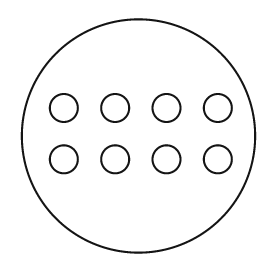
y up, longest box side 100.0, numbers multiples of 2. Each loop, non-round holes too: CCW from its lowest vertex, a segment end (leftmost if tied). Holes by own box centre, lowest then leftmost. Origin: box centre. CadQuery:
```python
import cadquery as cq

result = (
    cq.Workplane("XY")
    .moveTo(0.0, 0.0)
    .circle(50.0)
    .moveTo(-32.0, -10.0)
    .circle(6.0)
    .moveTo(-10.0, -10.0)
    .circle(6.0)
    .moveTo(12.0, -10.0)
    .circle(6.0)
    .moveTo(34.0, -10.0)
    .circle(6.0)
    .moveTo(-32.0, 12.0)
    .circle(6.0)
    .moveTo(-10.0, 12.0)
    .circle(6.0)
    .moveTo(12.0, 12.0)
    .circle(6.0)
    .moveTo(34.0, 12.0)
    .circle(6.0)
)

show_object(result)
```